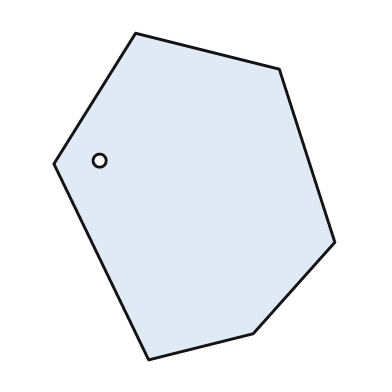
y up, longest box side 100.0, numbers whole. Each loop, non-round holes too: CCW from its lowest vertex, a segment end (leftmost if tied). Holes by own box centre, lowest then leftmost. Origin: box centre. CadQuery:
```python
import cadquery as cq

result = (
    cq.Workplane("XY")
    .moveTo(-14.0, -50.0)
    .lineTo(18.0, -42.0)
    .lineTo(43.0, -14.0)
    .lineTo(26.0, 39.0)
    .lineTo(-18.0, 50.0)
    .lineTo(-43.0, 10.0)
    .close()
    .moveTo(-29.0, 11.0)
    .circle(2.0)
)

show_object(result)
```